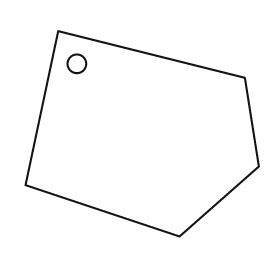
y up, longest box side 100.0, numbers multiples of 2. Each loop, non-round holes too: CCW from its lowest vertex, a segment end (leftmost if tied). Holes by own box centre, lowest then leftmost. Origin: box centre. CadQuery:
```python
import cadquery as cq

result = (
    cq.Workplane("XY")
    .moveTo(16.0, -44.0)
    .lineTo(50.0, -14.0)
    .lineTo(44.0, 24.0)
    .lineTo(-36.0, 44.0)
    .lineTo(-50.0, -22.0)
    .close()
    .moveTo(-28.0, 30.0)
    .circle(4.0)
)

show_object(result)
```